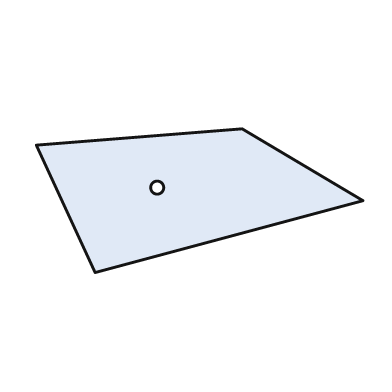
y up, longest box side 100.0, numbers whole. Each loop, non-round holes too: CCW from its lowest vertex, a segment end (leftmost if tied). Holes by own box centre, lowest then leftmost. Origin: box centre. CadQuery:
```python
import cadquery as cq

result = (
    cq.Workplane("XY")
    .moveTo(-32.0, -22.0)
    .lineTo(50.0, 0.0)
    .lineTo(13.0, 22.0)
    .lineTo(-50.0, 17.0)
    .close()
    .moveTo(-13.0, 4.0)
    .circle(2.0)
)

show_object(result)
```